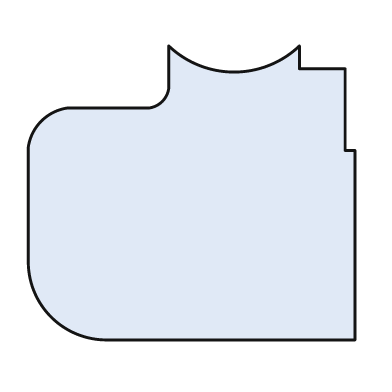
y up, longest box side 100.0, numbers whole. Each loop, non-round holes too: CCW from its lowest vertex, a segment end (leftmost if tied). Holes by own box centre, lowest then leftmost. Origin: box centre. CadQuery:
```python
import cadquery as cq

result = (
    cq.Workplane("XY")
    .moveTo(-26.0, -45.0)
    .lineTo(50.0, -45.0)
    .lineTo(50.0, 13.0)
    .lineTo(47.0, 13.0)
    .lineTo(47.0, 38.0)
    .lineTo(33.0, 38.0)
    .lineTo(33.0, 45.0)
    .threePointArc((13.0, 37.0), (-7.0, 45.0))
    .lineTo(-7.0, 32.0)
    .threePointArc((-9.0, 28.0), (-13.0, 26.0))
    .lineTo(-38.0, 26.0)
    .threePointArc((-46.0, 22.0), (-50.0, 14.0))
    .lineTo(-50.0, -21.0)
    .threePointArc((-43.0, -38.0), (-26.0, -45.0))
    .close()
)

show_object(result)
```